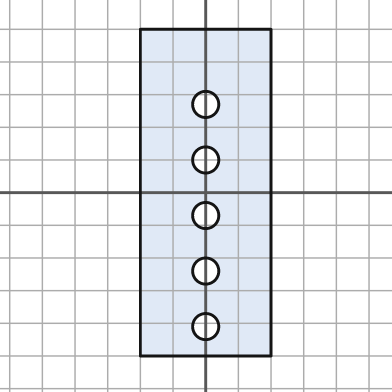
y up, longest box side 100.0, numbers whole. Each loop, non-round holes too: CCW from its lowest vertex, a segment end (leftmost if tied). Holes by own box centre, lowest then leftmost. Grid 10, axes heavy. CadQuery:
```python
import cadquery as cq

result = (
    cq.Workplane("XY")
    .moveTo(-20.0, -50.0)
    .lineTo(20.0, -50.0)
    .lineTo(20.0, 50.0)
    .lineTo(-20.0, 50.0)
    .close()
    .moveTo(0.0, -41.0)
    .circle(4.0)
    .moveTo(0.0, -24.0)
    .circle(4.0)
    .moveTo(0.0, -7.0)
    .circle(4.0)
    .moveTo(0.0, 10.0)
    .circle(4.0)
    .moveTo(0.0, 27.0)
    .circle(4.0)
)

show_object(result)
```